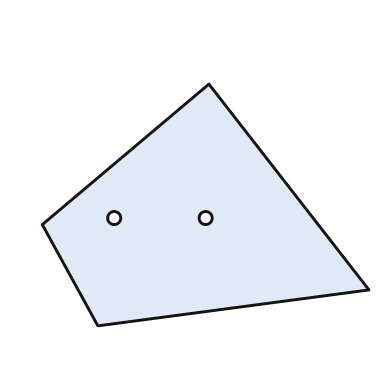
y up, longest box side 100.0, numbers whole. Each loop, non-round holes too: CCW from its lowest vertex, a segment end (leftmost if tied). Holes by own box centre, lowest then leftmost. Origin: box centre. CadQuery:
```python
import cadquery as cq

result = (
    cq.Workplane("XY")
    .moveTo(-33.0, -37.0)
    .lineTo(50.0, -26.0)
    .lineTo(1.0, 37.0)
    .lineTo(-50.0, -6.0)
    .close()
    .moveTo(-28.0, -4.0)
    .circle(2.0)
    .moveTo(0.0, -4.0)
    .circle(2.0)
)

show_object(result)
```